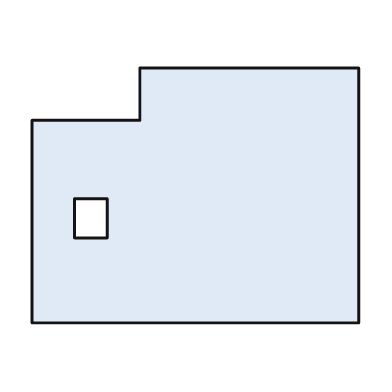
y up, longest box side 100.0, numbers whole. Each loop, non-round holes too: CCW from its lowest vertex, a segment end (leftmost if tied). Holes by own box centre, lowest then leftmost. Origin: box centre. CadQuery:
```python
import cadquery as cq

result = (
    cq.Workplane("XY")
    .moveTo(-50.0, -39.0)
    .lineTo(50.0, -39.0)
    .lineTo(50.0, 39.0)
    .lineTo(-17.0, 39.0)
    .lineTo(-17.0, 23.0)
    .lineTo(-50.0, 23.0)
    .close()
    .moveTo(-37.0, -13.0)
    .lineTo(-27.0, -13.0)
    .lineTo(-27.0, -1.0)
    .lineTo(-37.0, -1.0)
    .close()
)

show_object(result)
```